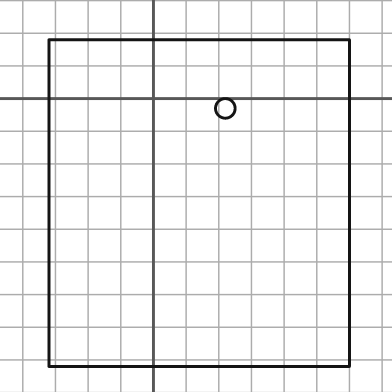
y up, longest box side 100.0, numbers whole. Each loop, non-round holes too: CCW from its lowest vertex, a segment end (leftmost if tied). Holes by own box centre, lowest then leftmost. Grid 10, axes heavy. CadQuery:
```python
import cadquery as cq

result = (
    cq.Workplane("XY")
    .moveTo(-32.0, -82.0)
    .lineTo(60.0, -82.0)
    .lineTo(60.0, 18.0)
    .lineTo(-32.0, 18.0)
    .close()
    .moveTo(22.0, -3.0)
    .circle(3.0)
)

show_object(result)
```